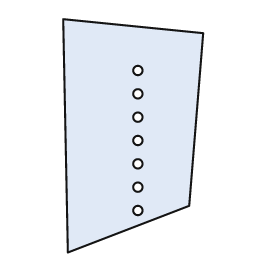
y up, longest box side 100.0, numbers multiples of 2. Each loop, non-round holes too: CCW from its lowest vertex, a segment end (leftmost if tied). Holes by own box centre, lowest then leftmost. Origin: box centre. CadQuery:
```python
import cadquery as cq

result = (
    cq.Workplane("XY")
    .moveTo(-28.0, -50.0)
    .lineTo(24.0, -30.0)
    .lineTo(30.0, 44.0)
    .lineTo(-30.0, 50.0)
    .close()
    .moveTo(2.0, -32.0)
    .circle(2.0)
    .moveTo(2.0, -22.0)
    .circle(2.0)
    .moveTo(2.0, -12.0)
    .circle(2.0)
    .moveTo(2.0, -2.0)
    .circle(2.0)
    .moveTo(2.0, 8.0)
    .circle(2.0)
    .moveTo(2.0, 18.0)
    .circle(2.0)
    .moveTo(2.0, 28.0)
    .circle(2.0)
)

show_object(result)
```